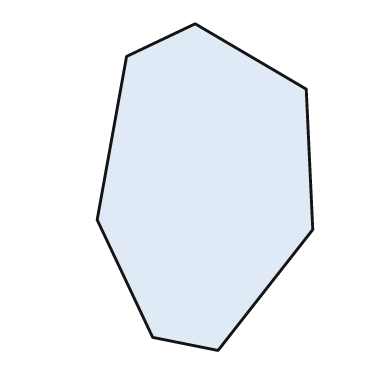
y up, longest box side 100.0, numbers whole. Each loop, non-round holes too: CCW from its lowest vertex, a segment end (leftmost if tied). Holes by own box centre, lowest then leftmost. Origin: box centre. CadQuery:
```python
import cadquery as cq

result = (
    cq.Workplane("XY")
    .moveTo(4.0, -50.0)
    .lineTo(33.0, -13.0)
    .lineTo(31.0, 30.0)
    .lineTo(-3.0, 50.0)
    .lineTo(-24.0, 40.0)
    .lineTo(-33.0, -10.0)
    .lineTo(-16.0, -46.0)
    .close()
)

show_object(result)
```